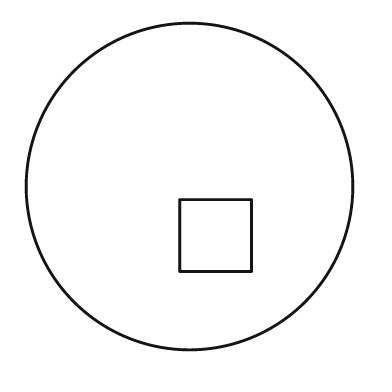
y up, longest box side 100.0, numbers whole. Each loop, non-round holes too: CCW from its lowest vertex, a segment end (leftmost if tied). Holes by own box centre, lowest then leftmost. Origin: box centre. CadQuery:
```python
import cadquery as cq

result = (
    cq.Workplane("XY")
    .moveTo(0.0, 0.0)
    .circle(50.0)
    .moveTo(-3.0, -26.0)
    .lineTo(19.0, -26.0)
    .lineTo(19.0, -4.0)
    .lineTo(-3.0, -4.0)
    .close()
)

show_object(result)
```